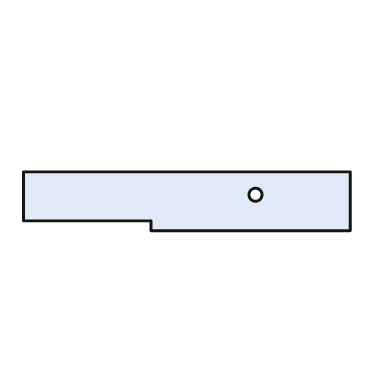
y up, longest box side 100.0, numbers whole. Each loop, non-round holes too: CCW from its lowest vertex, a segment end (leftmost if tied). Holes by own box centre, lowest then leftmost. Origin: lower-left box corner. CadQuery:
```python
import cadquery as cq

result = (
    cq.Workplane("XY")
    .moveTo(39.0, 0.0)
    .lineTo(100.0, 0.0)
    .lineTo(100.0, 18.0)
    .lineTo(0.0, 18.0)
    .lineTo(0.0, 3.0)
    .lineTo(39.0, 3.0)
    .close()
    .moveTo(71.0, 11.0)
    .circle(2.0)
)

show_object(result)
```